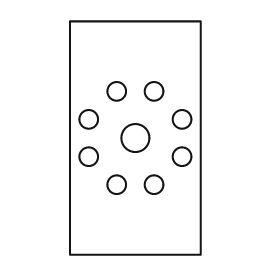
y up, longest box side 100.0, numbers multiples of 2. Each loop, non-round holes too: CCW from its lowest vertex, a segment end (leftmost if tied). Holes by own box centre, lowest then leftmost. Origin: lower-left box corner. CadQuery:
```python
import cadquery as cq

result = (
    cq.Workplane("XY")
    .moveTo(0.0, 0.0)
    .lineTo(56.0, 0.0)
    .lineTo(56.0, 100.0)
    .lineTo(0.0, 100.0)
    .close()
    .moveTo(20.0, 30.0)
    .circle(4.0)
    .moveTo(36.0, 30.0)
    .circle(4.0)
    .moveTo(8.0, 42.0)
    .circle(4.0)
    .moveTo(48.0, 42.0)
    .circle(4.0)
    .moveTo(28.0, 50.0)
    .circle(6.0)
    .moveTo(8.0, 58.0)
    .circle(4.0)
    .moveTo(48.0, 58.0)
    .circle(4.0)
    .moveTo(20.0, 70.0)
    .circle(4.0)
    .moveTo(36.0, 70.0)
    .circle(4.0)
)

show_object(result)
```